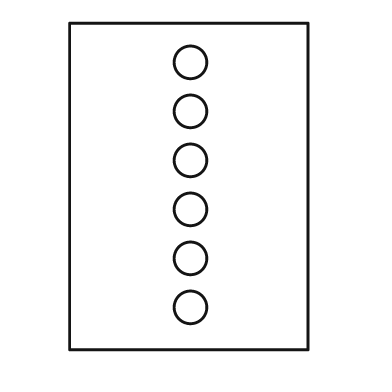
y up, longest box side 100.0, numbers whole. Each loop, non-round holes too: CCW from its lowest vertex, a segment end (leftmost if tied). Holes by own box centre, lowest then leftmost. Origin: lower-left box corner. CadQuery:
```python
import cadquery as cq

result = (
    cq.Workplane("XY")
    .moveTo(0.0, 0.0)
    .lineTo(73.0, 0.0)
    .lineTo(73.0, 100.0)
    .lineTo(0.0, 100.0)
    .close()
    .moveTo(37.0, 13.0)
    .circle(5.0)
    .moveTo(37.0, 28.0)
    .circle(5.0)
    .moveTo(37.0, 43.0)
    .circle(5.0)
    .moveTo(37.0, 58.0)
    .circle(5.0)
    .moveTo(37.0, 73.0)
    .circle(5.0)
    .moveTo(37.0, 88.0)
    .circle(5.0)
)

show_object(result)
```